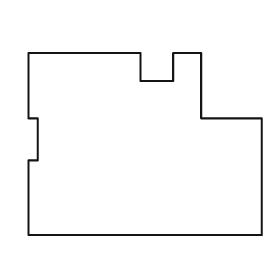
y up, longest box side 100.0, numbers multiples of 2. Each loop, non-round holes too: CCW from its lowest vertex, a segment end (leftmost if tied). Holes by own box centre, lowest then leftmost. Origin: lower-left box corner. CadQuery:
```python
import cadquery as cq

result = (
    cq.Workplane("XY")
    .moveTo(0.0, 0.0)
    .lineTo(100.0, 0.0)
    .lineTo(100.0, 50.0)
    .lineTo(74.0, 50.0)
    .lineTo(74.0, 78.0)
    .lineTo(62.0, 78.0)
    .lineTo(62.0, 66.0)
    .lineTo(48.0, 66.0)
    .lineTo(48.0, 78.0)
    .lineTo(0.0, 78.0)
    .lineTo(0.0, 50.0)
    .lineTo(4.0, 50.0)
    .lineTo(4.0, 32.0)
    .lineTo(0.0, 32.0)
    .close()
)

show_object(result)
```